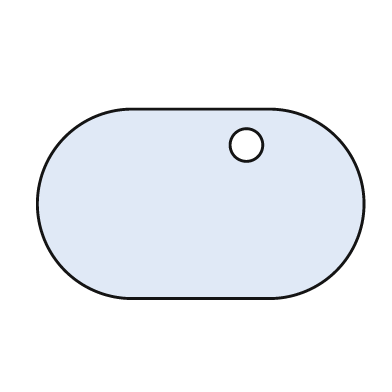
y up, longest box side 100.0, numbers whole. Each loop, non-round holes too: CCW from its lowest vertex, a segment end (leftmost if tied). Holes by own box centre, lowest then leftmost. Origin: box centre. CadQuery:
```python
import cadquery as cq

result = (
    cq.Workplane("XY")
    .moveTo(-21.0, -29.0)
    .lineTo(21.0, -29.0)
    .threePointArc((50.0, 0.0), (21.0, 29.0))
    .lineTo(-21.0, 29.0)
    .threePointArc((-50.0, 0.0), (-21.0, -29.0))
    .close()
    .moveTo(14.0, 18.0)
    .circle(5.0)
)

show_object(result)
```